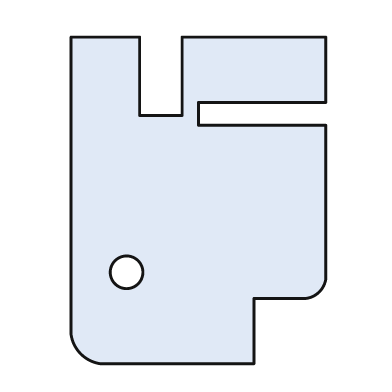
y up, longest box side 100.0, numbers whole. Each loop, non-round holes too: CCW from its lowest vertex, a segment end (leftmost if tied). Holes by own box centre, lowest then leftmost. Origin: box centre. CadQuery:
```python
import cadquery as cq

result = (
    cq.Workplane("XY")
    .moveTo(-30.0, -50.0)
    .lineTo(17.0, -50.0)
    .lineTo(17.0, -30.0)
    .lineTo(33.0, -30.0)
    .threePointArc((37.0, -28.0), (39.0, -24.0))
    .lineTo(39.0, 23.0)
    .lineTo(0.0, 23.0)
    .lineTo(0.0, 30.0)
    .lineTo(39.0, 30.0)
    .lineTo(39.0, 50.0)
    .lineTo(-5.0, 50.0)
    .lineTo(-5.0, 26.0)
    .lineTo(-18.0, 26.0)
    .lineTo(-18.0, 50.0)
    .lineTo(-39.0, 50.0)
    .lineTo(-39.0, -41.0)
    .threePointArc((-36.0, -47.0), (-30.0, -50.0))
    .close()
    .moveTo(-22.0, -22.0)
    .circle(5.0)
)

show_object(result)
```